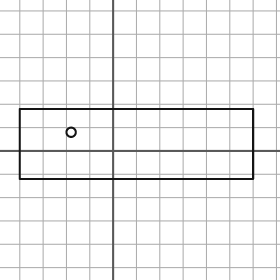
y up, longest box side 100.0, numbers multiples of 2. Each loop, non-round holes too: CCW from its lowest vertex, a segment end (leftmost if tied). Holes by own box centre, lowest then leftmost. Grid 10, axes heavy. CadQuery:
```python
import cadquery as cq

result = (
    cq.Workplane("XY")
    .moveTo(-40.0, -12.0)
    .lineTo(60.0, -12.0)
    .lineTo(60.0, 18.0)
    .lineTo(-40.0, 18.0)
    .close()
    .moveTo(-18.0, 8.0)
    .circle(2.0)
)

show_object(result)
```